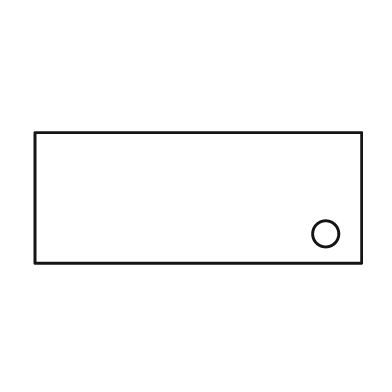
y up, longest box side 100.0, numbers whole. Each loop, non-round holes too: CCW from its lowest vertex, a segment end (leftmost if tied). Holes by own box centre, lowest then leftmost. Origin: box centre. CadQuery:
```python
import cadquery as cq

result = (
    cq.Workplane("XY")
    .moveTo(-50.0, -20.0)
    .lineTo(50.0, -20.0)
    .lineTo(50.0, 20.0)
    .lineTo(-50.0, 20.0)
    .close()
    .moveTo(39.0, -11.0)
    .circle(4.0)
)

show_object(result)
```